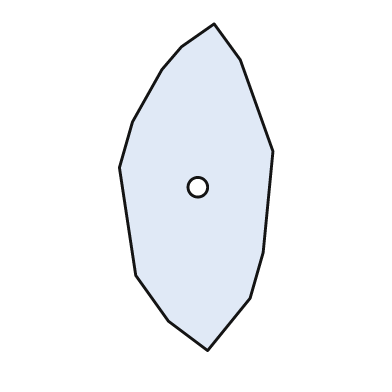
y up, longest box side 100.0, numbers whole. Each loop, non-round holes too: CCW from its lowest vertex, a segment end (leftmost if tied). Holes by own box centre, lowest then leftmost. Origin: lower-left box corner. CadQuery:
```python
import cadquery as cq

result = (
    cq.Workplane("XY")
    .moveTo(27.0, 0.0)
    .lineTo(40.0, 16.0)
    .lineTo(44.0, 30.0)
    .lineTo(47.0, 61.0)
    .lineTo(37.0, 89.0)
    .lineTo(29.0, 100.0)
    .lineTo(19.0, 93.0)
    .lineTo(13.0, 86.0)
    .lineTo(4.0, 70.0)
    .lineTo(0.0, 56.0)
    .lineTo(5.0, 23.0)
    .lineTo(15.0, 9.0)
    .close()
    .moveTo(24.0, 50.0)
    .circle(3.0)
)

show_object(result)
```